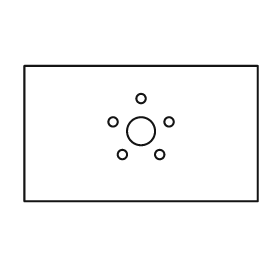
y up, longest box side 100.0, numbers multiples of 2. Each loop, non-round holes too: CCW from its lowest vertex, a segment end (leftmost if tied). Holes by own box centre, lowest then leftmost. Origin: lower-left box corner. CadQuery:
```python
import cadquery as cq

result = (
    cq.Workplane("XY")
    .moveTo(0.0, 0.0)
    .lineTo(100.0, 0.0)
    .lineTo(100.0, 58.0)
    .lineTo(0.0, 58.0)
    .close()
    .moveTo(42.0, 20.0)
    .circle(2.0)
    .moveTo(58.0, 20.0)
    .circle(2.0)
    .moveTo(50.0, 30.0)
    .circle(6.0)
    .moveTo(38.0, 34.0)
    .circle(2.0)
    .moveTo(62.0, 34.0)
    .circle(2.0)
    .moveTo(50.0, 44.0)
    .circle(2.0)
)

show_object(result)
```